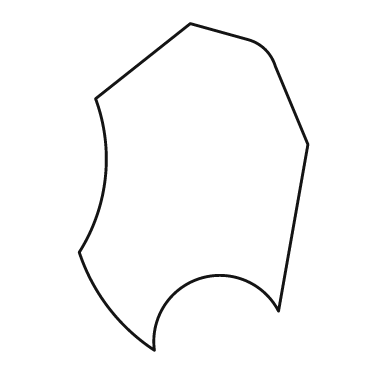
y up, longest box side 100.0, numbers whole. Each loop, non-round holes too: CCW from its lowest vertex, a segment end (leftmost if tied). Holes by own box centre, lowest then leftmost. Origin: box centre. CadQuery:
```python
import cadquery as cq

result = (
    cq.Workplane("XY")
    .moveTo(-12.0, -50.0)
    .threePointArc((2.0, -28.0), (26.0, -38.0))
    .lineTo(35.0, 13.0)
    .lineTo(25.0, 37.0)
    .threePointArc((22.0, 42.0), (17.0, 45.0))
    .lineTo(-1.0, 50.0)
    .lineTo(-30.0, 27.0)
    .threePointArc((-27.0, 3.0), (-35.0, -20.0))
    .threePointArc((-26.0, -37.0), (-12.0, -50.0))
    .close()
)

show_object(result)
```